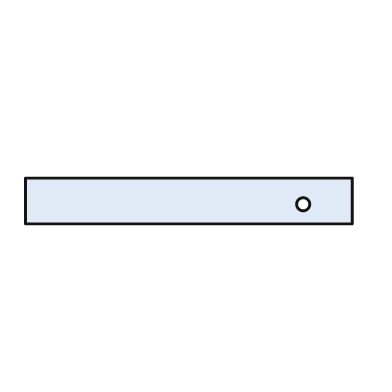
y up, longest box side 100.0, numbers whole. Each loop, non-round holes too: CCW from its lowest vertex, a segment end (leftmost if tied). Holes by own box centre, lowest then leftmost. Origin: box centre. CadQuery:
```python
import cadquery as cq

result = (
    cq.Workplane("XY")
    .moveTo(-50.0, -7.0)
    .lineTo(50.0, -7.0)
    .lineTo(50.0, 7.0)
    .lineTo(-50.0, 7.0)
    .close()
    .moveTo(35.0, -1.0)
    .circle(2.0)
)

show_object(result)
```